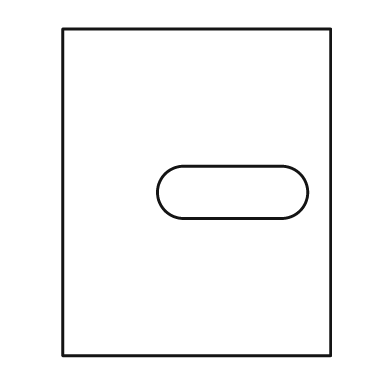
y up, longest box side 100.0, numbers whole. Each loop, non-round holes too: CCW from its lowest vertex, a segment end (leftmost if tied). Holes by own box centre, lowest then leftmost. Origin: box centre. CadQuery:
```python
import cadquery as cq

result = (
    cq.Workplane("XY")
    .moveTo(-41.0, -50.0)
    .lineTo(41.0, -50.0)
    .lineTo(41.0, 50.0)
    .lineTo(-41.0, 50.0)
    .close()
    .moveTo(-4.0, -8.0)
    .lineTo(26.0, -8.0)
    .threePointArc((34.0, 0.0), (26.0, 8.0))
    .lineTo(-4.0, 8.0)
    .threePointArc((-12.0, 0.0), (-4.0, -8.0))
    .close()
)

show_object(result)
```